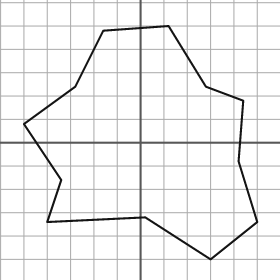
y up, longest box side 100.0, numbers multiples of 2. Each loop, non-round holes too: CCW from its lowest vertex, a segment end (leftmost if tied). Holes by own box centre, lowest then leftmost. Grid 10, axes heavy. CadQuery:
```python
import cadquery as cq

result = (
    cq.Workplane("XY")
    .moveTo(30.0, -50.0)
    .lineTo(50.0, -34.0)
    .lineTo(42.0, -8.0)
    .lineTo(44.0, 18.0)
    .lineTo(28.0, 24.0)
    .lineTo(12.0, 50.0)
    .lineTo(-16.0, 48.0)
    .lineTo(-28.0, 24.0)
    .lineTo(-50.0, 8.0)
    .lineTo(-34.0, -16.0)
    .lineTo(-40.0, -34.0)
    .lineTo(2.0, -32.0)
    .close()
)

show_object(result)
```